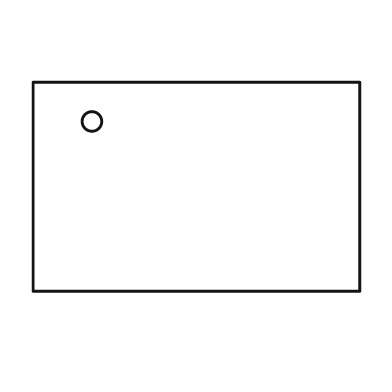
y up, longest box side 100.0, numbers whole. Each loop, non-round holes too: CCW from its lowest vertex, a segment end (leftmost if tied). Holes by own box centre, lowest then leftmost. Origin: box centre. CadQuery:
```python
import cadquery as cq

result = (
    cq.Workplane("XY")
    .moveTo(-50.0, -32.0)
    .lineTo(50.0, -32.0)
    .lineTo(50.0, 32.0)
    .lineTo(-50.0, 32.0)
    .close()
    .moveTo(-32.0, 20.0)
    .circle(3.0)
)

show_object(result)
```